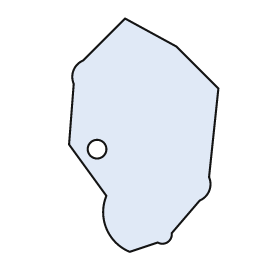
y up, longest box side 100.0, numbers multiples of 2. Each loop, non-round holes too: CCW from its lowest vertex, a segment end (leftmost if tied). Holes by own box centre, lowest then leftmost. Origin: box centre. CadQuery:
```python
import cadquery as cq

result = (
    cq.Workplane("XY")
    .moveTo(-6.0, -50.0)
    .lineTo(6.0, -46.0)
    .threePointArc((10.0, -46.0), (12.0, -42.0))
    .lineTo(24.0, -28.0)
    .threePointArc((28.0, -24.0), (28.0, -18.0))
    .lineTo(32.0, 20.0)
    .lineTo(14.0, 38.0)
    .lineTo(-8.0, 50.0)
    .lineTo(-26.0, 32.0)
    .threePointArc((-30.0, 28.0), (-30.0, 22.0))
    .lineTo(-32.0, -4.0)
    .lineTo(-16.0, -26.0)
    .threePointArc((-16.0, -40.0), (-6.0, -50.0))
    .close()
    .moveTo(-20.0, -6.0)
    .circle(4.0)
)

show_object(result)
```